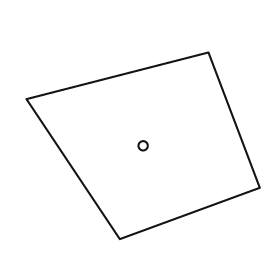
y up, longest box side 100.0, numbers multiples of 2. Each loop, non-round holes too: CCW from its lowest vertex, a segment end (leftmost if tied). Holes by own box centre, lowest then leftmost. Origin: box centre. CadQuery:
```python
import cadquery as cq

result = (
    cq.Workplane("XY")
    .moveTo(-10.0, -40.0)
    .lineTo(50.0, -18.0)
    .lineTo(28.0, 40.0)
    .lineTo(-50.0, 20.0)
    .close()
    .moveTo(0.0, 0.0)
    .circle(2.0)
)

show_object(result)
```